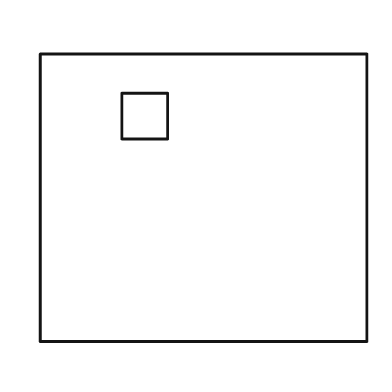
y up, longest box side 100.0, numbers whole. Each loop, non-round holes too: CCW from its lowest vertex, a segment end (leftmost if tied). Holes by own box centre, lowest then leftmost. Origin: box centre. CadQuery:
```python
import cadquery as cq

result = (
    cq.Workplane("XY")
    .moveTo(-50.0, -44.0)
    .lineTo(50.0, -44.0)
    .lineTo(50.0, 44.0)
    .lineTo(-50.0, 44.0)
    .close()
    .moveTo(-25.0, 18.0)
    .lineTo(-11.0, 18.0)
    .lineTo(-11.0, 32.0)
    .lineTo(-25.0, 32.0)
    .close()
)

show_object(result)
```